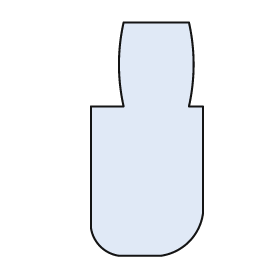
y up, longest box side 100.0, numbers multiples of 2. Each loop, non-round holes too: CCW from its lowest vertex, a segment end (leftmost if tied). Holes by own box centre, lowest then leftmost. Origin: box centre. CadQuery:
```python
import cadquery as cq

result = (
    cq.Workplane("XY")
    .moveTo(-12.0, -50.0)
    .lineTo(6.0, -50.0)
    .threePointArc((18.0, -44.0), (24.0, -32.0))
    .lineTo(24.0, 14.0)
    .lineTo(18.0, 14.0)
    .threePointArc((20.0, 32.0), (18.0, 50.0))
    .lineTo(-10.0, 50.0)
    .threePointArc((-12.0, 32.0), (-10.0, 14.0))
    .lineTo(-24.0, 14.0)
    .lineTo(-24.0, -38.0)
    .threePointArc((-20.0, -46.0), (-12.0, -50.0))
    .close()
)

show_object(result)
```